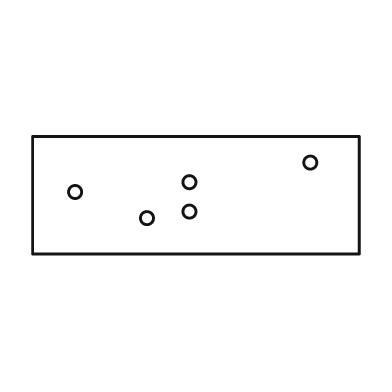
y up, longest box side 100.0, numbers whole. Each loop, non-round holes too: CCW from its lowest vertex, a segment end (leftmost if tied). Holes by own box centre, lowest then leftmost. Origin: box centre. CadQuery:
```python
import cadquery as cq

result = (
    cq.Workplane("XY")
    .moveTo(-50.0, -18.0)
    .lineTo(50.0, -18.0)
    .lineTo(50.0, 18.0)
    .lineTo(-50.0, 18.0)
    .close()
    .moveTo(-15.0, -7.0)
    .circle(2.0)
    .moveTo(-2.0, -5.0)
    .circle(2.0)
    .moveTo(-37.0, 1.0)
    .circle(2.0)
    .moveTo(-2.0, 4.0)
    .circle(2.0)
    .moveTo(35.0, 10.0)
    .circle(2.0)
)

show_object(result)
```